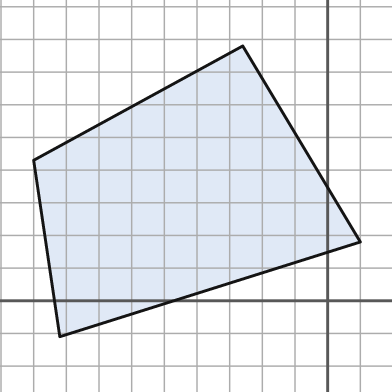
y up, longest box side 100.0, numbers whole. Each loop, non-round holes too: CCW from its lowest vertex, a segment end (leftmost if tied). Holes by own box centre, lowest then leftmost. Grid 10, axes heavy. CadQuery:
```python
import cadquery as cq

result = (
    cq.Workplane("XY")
    .moveTo(-82.0, -11.0)
    .lineTo(10.0, 18.0)
    .lineTo(-26.0, 78.0)
    .lineTo(-90.0, 43.0)
    .close()
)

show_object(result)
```